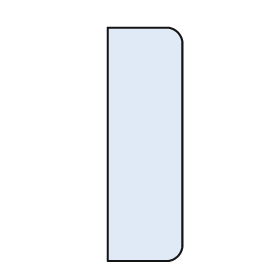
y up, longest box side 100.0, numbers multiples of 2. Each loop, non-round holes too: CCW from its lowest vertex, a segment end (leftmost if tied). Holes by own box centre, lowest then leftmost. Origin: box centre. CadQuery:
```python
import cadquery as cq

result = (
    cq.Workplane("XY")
    .moveTo(-16.0, -50.0)
    .lineTo(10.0, -50.0)
    .threePointArc((14.0, -48.0), (16.0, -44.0))
    .lineTo(16.0, 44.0)
    .threePointArc((14.0, 48.0), (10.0, 50.0))
    .lineTo(-16.0, 50.0)
    .close()
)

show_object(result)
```